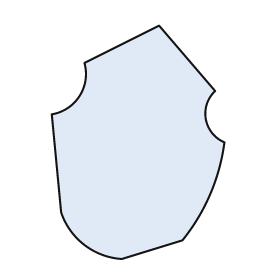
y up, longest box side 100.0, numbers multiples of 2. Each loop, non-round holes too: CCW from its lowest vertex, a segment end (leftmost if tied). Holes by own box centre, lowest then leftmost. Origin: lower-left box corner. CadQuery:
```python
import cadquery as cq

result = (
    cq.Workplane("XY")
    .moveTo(30.0, 0.0)
    .lineTo(56.0, 8.0)
    .threePointArc((68.0, 28.0), (74.0, 50.0))
    .threePointArc((66.0, 60.0), (70.0, 72.0))
    .lineTo(46.0, 100.0)
    .lineTo(14.0, 84.0)
    .threePointArc((12.0, 70.0), (0.0, 62.0))
    .lineTo(4.0, 20.0)
    .threePointArc((14.0, 6.0), (30.0, 0.0))
    .close()
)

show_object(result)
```